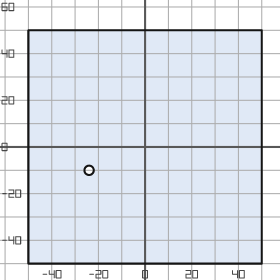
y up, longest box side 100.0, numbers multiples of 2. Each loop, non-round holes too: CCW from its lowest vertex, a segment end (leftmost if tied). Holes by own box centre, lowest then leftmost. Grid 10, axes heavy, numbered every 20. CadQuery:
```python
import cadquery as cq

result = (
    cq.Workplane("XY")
    .moveTo(-50.0, -50.0)
    .lineTo(50.0, -50.0)
    .lineTo(50.0, 50.0)
    .lineTo(-50.0, 50.0)
    .close()
    .moveTo(-24.0, -10.0)
    .circle(2.0)
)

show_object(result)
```